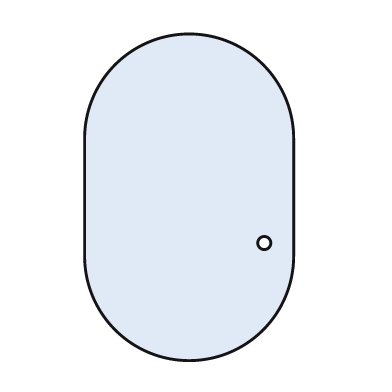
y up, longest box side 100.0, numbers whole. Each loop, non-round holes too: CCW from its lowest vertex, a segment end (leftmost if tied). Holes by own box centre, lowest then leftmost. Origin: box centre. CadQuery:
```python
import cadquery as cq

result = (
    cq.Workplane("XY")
    .moveTo(-32.0, -18.0)
    .threePointArc((0.0, -50.0), (32.0, -18.0))
    .lineTo(32.0, 18.0)
    .threePointArc((0.0, 50.0), (-32.0, 18.0))
    .close()
    .moveTo(23.0, -14.0)
    .circle(2.0)
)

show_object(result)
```